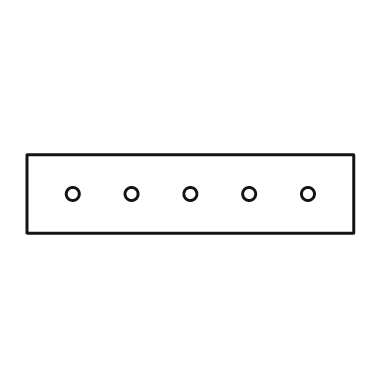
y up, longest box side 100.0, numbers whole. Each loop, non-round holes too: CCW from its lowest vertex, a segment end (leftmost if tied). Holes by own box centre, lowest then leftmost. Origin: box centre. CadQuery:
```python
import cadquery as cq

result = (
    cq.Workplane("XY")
    .moveTo(-50.0, -12.0)
    .lineTo(50.0, -12.0)
    .lineTo(50.0, 12.0)
    .lineTo(-50.0, 12.0)
    .close()
    .moveTo(-36.0, 0.0)
    .circle(2.0)
    .moveTo(-18.0, 0.0)
    .circle(2.0)
    .moveTo(0.0, 0.0)
    .circle(2.0)
    .moveTo(18.0, 0.0)
    .circle(2.0)
    .moveTo(36.0, 0.0)
    .circle(2.0)
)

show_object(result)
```